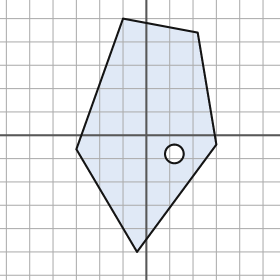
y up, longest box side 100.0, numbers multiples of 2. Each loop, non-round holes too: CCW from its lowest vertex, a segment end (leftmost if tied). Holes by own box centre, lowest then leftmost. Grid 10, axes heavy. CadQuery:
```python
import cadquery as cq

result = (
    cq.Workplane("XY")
    .moveTo(-4.0, -50.0)
    .lineTo(30.0, -4.0)
    .lineTo(22.0, 44.0)
    .lineTo(-10.0, 50.0)
    .lineTo(-30.0, -6.0)
    .close()
    .moveTo(12.0, -8.0)
    .circle(4.0)
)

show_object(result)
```